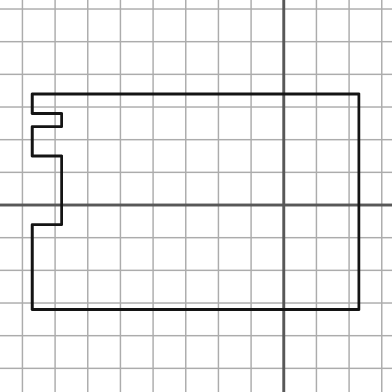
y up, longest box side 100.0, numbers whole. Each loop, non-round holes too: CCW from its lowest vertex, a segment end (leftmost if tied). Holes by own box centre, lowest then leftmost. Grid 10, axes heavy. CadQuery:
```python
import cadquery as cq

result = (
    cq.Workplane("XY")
    .moveTo(-77.0, -32.0)
    .lineTo(23.0, -32.0)
    .lineTo(23.0, 34.0)
    .lineTo(-77.0, 34.0)
    .lineTo(-77.0, 28.0)
    .lineTo(-68.0, 28.0)
    .lineTo(-68.0, 24.0)
    .lineTo(-77.0, 24.0)
    .lineTo(-77.0, 15.0)
    .lineTo(-68.0, 15.0)
    .lineTo(-68.0, -6.0)
    .lineTo(-77.0, -6.0)
    .close()
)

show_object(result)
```